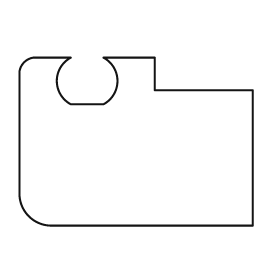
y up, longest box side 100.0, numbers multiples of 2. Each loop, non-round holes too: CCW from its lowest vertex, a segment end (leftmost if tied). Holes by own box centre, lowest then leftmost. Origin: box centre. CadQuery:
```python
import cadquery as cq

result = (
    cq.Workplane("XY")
    .moveTo(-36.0, -36.0)
    .lineTo(50.0, -36.0)
    .lineTo(50.0, 22.0)
    .lineTo(8.0, 22.0)
    .lineTo(8.0, 36.0)
    .lineTo(-14.0, 36.0)
    .threePointArc((-8.0, 26.0), (-14.0, 16.0))
    .lineTo(-28.0, 16.0)
    .threePointArc((-34.0, 26.0), (-28.0, 36.0))
    .lineTo(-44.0, 36.0)
    .threePointArc((-48.0, 34.0), (-50.0, 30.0))
    .lineTo(-50.0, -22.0)
    .threePointArc((-46.0, -32.0), (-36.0, -36.0))
    .close()
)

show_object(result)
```